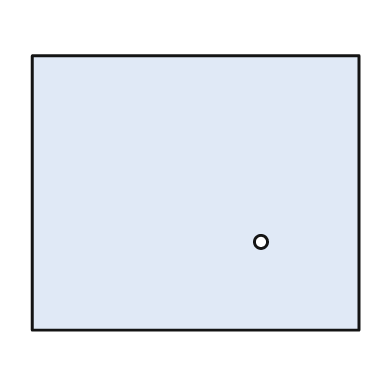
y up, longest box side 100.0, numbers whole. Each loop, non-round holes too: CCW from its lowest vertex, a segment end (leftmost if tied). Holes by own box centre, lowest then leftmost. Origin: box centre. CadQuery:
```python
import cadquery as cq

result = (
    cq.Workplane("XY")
    .moveTo(-50.0, -42.0)
    .lineTo(50.0, -42.0)
    .lineTo(50.0, 42.0)
    .lineTo(-50.0, 42.0)
    .close()
    .moveTo(20.0, -15.0)
    .circle(2.0)
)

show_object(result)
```